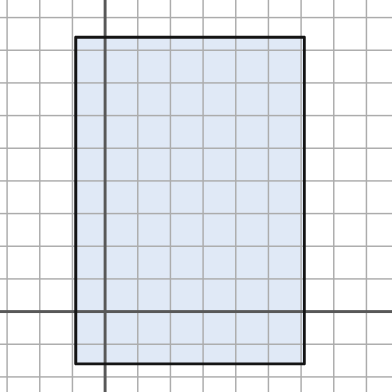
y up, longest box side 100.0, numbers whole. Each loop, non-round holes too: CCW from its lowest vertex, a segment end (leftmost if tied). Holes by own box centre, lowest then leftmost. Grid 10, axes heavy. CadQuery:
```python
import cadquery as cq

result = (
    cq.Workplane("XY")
    .moveTo(-9.0, -16.0)
    .lineTo(61.0, -16.0)
    .lineTo(61.0, 84.0)
    .lineTo(-9.0, 84.0)
    .close()
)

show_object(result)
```